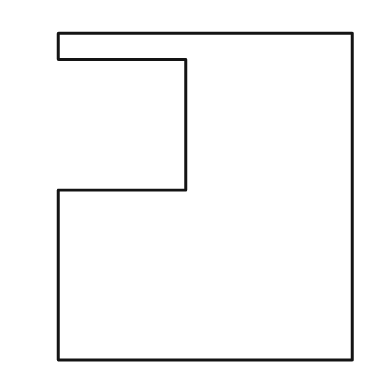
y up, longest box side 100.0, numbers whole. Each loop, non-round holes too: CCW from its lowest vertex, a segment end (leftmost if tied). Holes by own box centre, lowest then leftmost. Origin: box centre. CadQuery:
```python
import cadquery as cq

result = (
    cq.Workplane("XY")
    .moveTo(-45.0, -50.0)
    .lineTo(45.0, -50.0)
    .lineTo(45.0, 50.0)
    .lineTo(-45.0, 50.0)
    .lineTo(-45.0, 42.0)
    .lineTo(-6.0, 42.0)
    .lineTo(-6.0, 2.0)
    .lineTo(-45.0, 2.0)
    .close()
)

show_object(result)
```